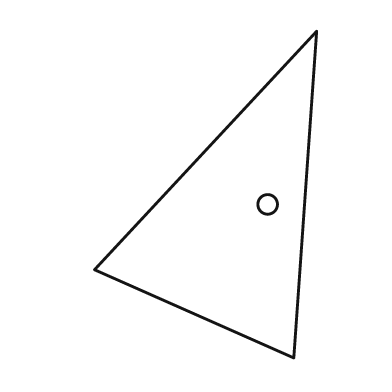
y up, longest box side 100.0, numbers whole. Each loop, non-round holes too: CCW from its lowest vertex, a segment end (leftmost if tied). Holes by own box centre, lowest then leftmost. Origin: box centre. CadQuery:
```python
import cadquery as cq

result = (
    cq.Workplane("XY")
    .moveTo(27.0, -50.0)
    .lineTo(34.0, 50.0)
    .lineTo(-34.0, -23.0)
    .close()
    .moveTo(19.0, -3.0)
    .circle(3.0)
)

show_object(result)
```